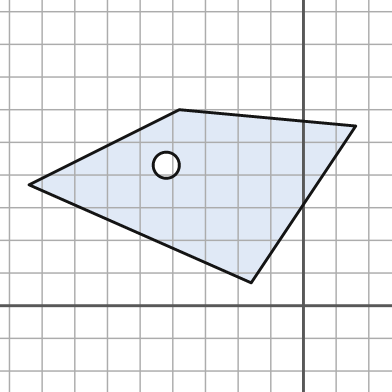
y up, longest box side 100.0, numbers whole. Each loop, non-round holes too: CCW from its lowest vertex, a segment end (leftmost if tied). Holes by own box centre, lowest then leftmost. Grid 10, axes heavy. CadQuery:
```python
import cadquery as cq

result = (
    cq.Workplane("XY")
    .moveTo(-16.0, 7.0)
    .lineTo(16.0, 55.0)
    .lineTo(-38.0, 60.0)
    .lineTo(-84.0, 37.0)
    .close()
    .moveTo(-42.0, 43.0)
    .circle(4.0)
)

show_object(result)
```